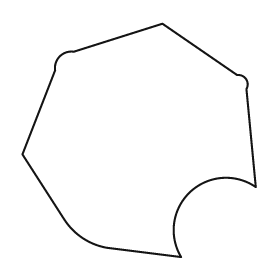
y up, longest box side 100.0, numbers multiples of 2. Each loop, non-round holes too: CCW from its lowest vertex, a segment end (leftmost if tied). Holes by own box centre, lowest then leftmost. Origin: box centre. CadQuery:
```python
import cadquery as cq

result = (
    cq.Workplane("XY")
    .moveTo(18.0, -50.0)
    .threePointArc((22.0, -22.0), (50.0, -20.0))
    .lineTo(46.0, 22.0)
    .threePointArc((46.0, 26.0), (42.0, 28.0))
    .lineTo(10.0, 50.0)
    .lineTo(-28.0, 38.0)
    .threePointArc((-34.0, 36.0), (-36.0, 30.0))
    .lineTo(-50.0, -6.0)
    .lineTo(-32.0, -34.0)
    .threePointArc((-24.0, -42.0), (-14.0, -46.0))
    .close()
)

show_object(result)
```